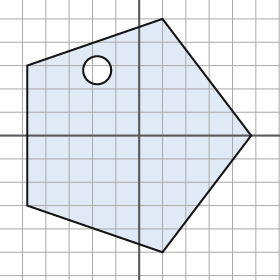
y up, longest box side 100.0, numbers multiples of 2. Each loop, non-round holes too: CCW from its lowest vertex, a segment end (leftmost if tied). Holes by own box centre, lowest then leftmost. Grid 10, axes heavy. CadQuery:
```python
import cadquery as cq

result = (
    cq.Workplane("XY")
    .moveTo(10.0, -50.0)
    .lineTo(48.0, 0.0)
    .lineTo(10.0, 50.0)
    .lineTo(-48.0, 30.0)
    .lineTo(-48.0, -30.0)
    .close()
    .moveTo(-18.0, 28.0)
    .circle(6.0)
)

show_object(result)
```